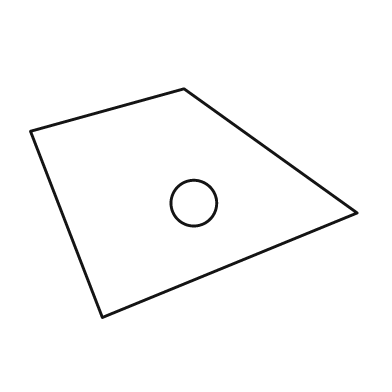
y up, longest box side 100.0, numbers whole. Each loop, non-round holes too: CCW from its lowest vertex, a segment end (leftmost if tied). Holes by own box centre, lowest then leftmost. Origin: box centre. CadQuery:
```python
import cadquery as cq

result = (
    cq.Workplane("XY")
    .moveTo(-28.0, -35.0)
    .lineTo(50.0, -3.0)
    .lineTo(-3.0, 35.0)
    .lineTo(-50.0, 22.0)
    .close()
    .moveTo(0.0, 0.0)
    .circle(7.0)
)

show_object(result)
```